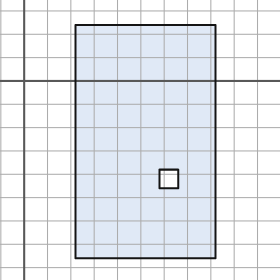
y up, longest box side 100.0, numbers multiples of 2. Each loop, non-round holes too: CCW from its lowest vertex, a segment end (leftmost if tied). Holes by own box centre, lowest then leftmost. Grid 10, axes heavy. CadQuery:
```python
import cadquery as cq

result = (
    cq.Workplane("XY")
    .moveTo(22.0, -76.0)
    .lineTo(82.0, -76.0)
    .lineTo(82.0, 24.0)
    .lineTo(22.0, 24.0)
    .close()
    .moveTo(58.0, -46.0)
    .lineTo(66.0, -46.0)
    .lineTo(66.0, -38.0)
    .lineTo(58.0, -38.0)
    .close()
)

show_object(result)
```